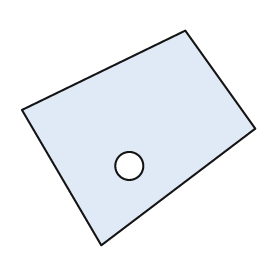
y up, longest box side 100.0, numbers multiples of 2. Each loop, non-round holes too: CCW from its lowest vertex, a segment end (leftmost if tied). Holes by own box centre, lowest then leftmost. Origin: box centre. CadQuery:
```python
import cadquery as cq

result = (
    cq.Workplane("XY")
    .moveTo(-16.0, -46.0)
    .lineTo(50.0, 4.0)
    .lineTo(20.0, 46.0)
    .lineTo(-50.0, 12.0)
    .close()
    .moveTo(-4.0, -12.0)
    .circle(6.0)
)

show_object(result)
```